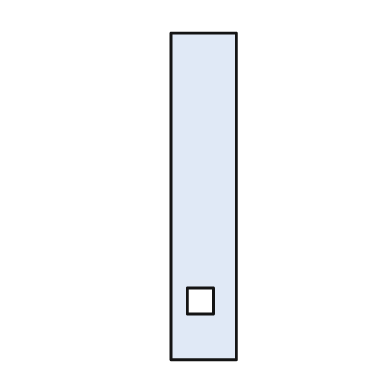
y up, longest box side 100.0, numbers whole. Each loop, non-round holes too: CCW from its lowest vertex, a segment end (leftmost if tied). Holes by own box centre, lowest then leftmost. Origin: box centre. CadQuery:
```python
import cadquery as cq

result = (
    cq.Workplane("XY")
    .moveTo(-10.0, -50.0)
    .lineTo(10.0, -50.0)
    .lineTo(10.0, 50.0)
    .lineTo(-10.0, 50.0)
    .close()
    .moveTo(-5.0, -36.0)
    .lineTo(3.0, -36.0)
    .lineTo(3.0, -28.0)
    .lineTo(-5.0, -28.0)
    .close()
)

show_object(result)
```